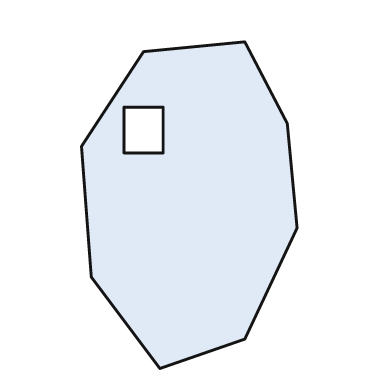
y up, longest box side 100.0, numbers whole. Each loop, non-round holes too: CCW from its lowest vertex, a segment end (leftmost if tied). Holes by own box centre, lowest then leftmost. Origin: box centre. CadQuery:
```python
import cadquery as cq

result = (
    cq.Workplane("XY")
    .moveTo(-9.0, -50.0)
    .lineTo(17.0, -41.0)
    .lineTo(33.0, -7.0)
    .lineTo(30.0, 25.0)
    .lineTo(17.0, 50.0)
    .lineTo(-14.0, 47.0)
    .lineTo(-33.0, 18.0)
    .lineTo(-30.0, -22.0)
    .close()
    .moveTo(-20.0, 16.0)
    .lineTo(-8.0, 16.0)
    .lineTo(-8.0, 30.0)
    .lineTo(-20.0, 30.0)
    .close()
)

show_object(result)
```